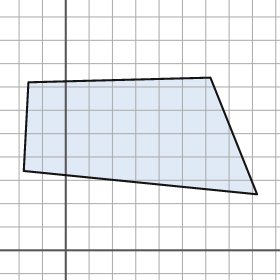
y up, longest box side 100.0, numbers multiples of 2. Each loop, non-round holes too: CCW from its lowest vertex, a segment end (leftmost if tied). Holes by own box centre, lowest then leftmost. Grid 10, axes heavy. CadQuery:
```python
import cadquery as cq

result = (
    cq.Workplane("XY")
    .moveTo(82.0, 24.0)
    .lineTo(62.0, 74.0)
    .lineTo(-16.0, 72.0)
    .lineTo(-18.0, 34.0)
    .close()
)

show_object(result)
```